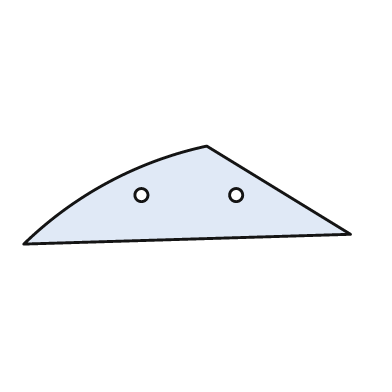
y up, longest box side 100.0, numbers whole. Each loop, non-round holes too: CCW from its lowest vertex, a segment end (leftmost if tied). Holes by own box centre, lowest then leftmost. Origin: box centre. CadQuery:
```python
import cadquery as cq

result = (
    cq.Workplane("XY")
    .moveTo(-50.0, -15.0)
    .lineTo(50.0, -12.0)
    .lineTo(6.0, 15.0)
    .threePointArc((-24.0, 4.0), (-50.0, -15.0))
    .close()
    .moveTo(-14.0, 0.0)
    .circle(2.0)
    .moveTo(15.0, 0.0)
    .circle(2.0)
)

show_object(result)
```